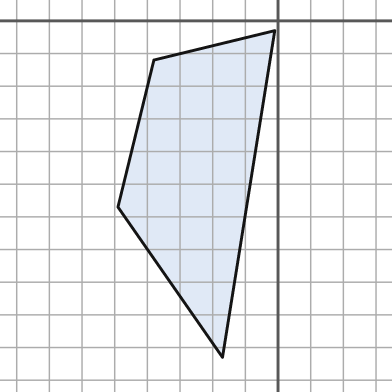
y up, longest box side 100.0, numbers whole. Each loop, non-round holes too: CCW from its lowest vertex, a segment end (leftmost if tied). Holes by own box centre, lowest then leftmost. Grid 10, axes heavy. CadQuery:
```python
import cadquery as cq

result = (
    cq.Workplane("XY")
    .moveTo(-17.0, -103.0)
    .lineTo(-1.0, -3.0)
    .lineTo(-38.0, -12.0)
    .lineTo(-49.0, -57.0)
    .close()
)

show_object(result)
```